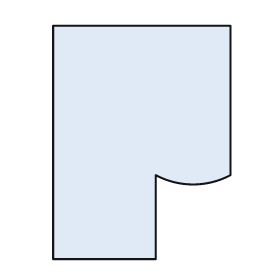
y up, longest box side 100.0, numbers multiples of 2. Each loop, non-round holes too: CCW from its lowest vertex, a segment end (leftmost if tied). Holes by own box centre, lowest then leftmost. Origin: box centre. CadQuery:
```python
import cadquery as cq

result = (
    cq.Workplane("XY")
    .moveTo(-38.0, -50.0)
    .lineTo(6.0, -50.0)
    .lineTo(6.0, -14.0)
    .threePointArc((22.0, -18.0), (38.0, -14.0))
    .lineTo(38.0, 50.0)
    .lineTo(-38.0, 50.0)
    .close()
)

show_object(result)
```